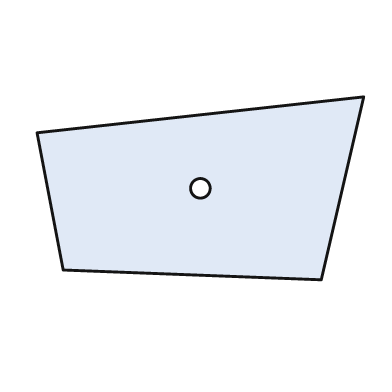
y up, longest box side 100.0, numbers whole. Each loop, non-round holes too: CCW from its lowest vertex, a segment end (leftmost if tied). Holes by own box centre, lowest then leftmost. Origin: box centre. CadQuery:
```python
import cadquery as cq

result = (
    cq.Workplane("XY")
    .moveTo(37.0, -28.0)
    .lineTo(50.0, 28.0)
    .lineTo(-50.0, 17.0)
    .lineTo(-42.0, -25.0)
    .close()
    .moveTo(0.0, 0.0)
    .circle(3.0)
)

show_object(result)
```